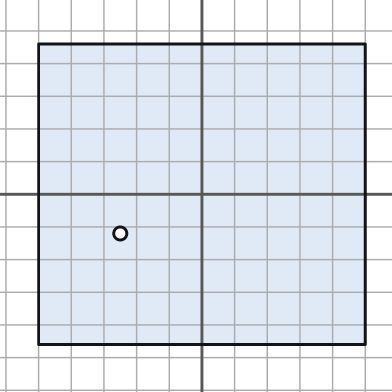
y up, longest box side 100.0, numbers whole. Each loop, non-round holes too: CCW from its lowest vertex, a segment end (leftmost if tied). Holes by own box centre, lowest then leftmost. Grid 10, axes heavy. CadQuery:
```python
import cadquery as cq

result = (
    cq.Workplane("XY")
    .moveTo(-50.0, -46.0)
    .lineTo(50.0, -46.0)
    .lineTo(50.0, 46.0)
    .lineTo(-50.0, 46.0)
    .close()
    .moveTo(-25.0, -12.0)
    .circle(2.0)
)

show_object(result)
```